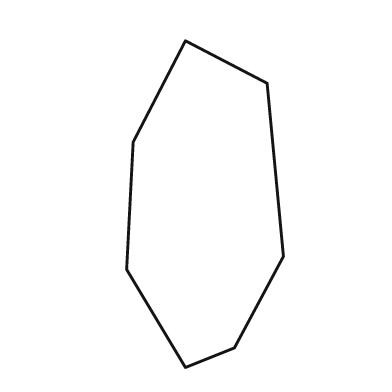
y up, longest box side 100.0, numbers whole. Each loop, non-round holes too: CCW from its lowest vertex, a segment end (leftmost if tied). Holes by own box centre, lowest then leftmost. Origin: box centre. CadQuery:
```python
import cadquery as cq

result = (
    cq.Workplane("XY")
    .moveTo(-6.0, -50.0)
    .lineTo(9.0, -44.0)
    .lineTo(24.0, -16.0)
    .lineTo(19.0, 37.0)
    .lineTo(-6.0, 50.0)
    .lineTo(-22.0, 19.0)
    .lineTo(-24.0, -20.0)
    .close()
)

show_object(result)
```